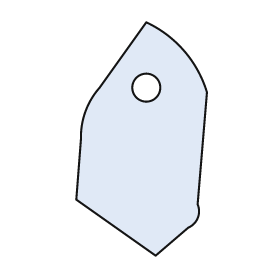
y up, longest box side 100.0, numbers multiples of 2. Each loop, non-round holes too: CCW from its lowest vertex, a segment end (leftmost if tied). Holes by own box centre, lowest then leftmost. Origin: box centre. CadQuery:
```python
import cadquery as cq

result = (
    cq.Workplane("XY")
    .moveTo(6.0, -50.0)
    .lineTo(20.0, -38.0)
    .threePointArc((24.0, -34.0), (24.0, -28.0))
    .lineTo(28.0, 20.0)
    .threePointArc((18.0, 38.0), (2.0, 50.0))
    .lineTo(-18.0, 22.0)
    .threePointArc((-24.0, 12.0), (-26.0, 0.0))
    .lineTo(-28.0, -26.0)
    .close()
    .moveTo(2.0, 22.0)
    .circle(6.0)
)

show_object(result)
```